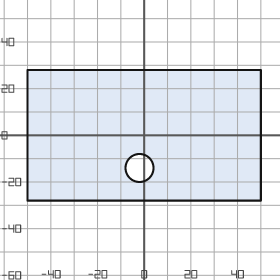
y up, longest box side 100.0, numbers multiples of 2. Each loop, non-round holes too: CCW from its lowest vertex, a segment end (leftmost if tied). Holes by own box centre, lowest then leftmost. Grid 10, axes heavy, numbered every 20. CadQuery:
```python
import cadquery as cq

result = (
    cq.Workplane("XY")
    .moveTo(-50.0, -28.0)
    .lineTo(50.0, -28.0)
    .lineTo(50.0, 28.0)
    .lineTo(-50.0, 28.0)
    .close()
    .moveTo(-2.0, -14.0)
    .circle(6.0)
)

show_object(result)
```